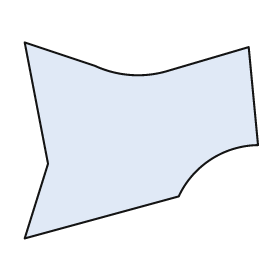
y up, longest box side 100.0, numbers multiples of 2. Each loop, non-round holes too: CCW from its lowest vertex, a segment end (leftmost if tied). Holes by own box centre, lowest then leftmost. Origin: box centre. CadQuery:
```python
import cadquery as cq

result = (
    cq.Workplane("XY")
    .moveTo(-50.0, -42.0)
    .lineTo(16.0, -24.0)
    .threePointArc((30.0, -8.0), (50.0, -2.0))
    .lineTo(46.0, 40.0)
    .lineTo(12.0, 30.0)
    .threePointArc((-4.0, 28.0), (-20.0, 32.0))
    .lineTo(-50.0, 42.0)
    .lineTo(-40.0, -10.0)
    .close()
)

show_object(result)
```